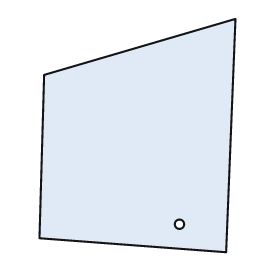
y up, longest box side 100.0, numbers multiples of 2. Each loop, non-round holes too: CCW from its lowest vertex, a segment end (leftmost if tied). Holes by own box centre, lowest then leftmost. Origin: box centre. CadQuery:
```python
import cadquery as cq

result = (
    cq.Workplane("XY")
    .moveTo(38.0, -50.0)
    .lineTo(42.0, 50.0)
    .lineTo(-40.0, 26.0)
    .lineTo(-42.0, -44.0)
    .close()
    .moveTo(18.0, -38.0)
    .circle(2.0)
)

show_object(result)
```